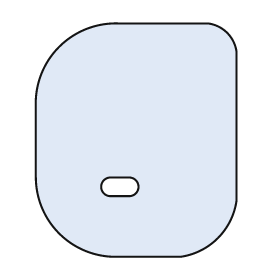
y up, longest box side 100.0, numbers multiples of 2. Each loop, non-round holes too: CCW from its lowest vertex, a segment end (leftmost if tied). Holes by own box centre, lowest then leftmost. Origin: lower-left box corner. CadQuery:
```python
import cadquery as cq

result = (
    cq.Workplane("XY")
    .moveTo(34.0, 0.0)
    .lineTo(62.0, 0.0)
    .threePointArc((78.0, 8.0), (86.0, 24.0))
    .lineTo(86.0, 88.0)
    .threePointArc((82.0, 96.0), (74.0, 100.0))
    .lineTo(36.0, 100.0)
    .threePointArc((10.0, 90.0), (0.0, 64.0))
    .lineTo(0.0, 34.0)
    .threePointArc((10.0, 10.0), (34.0, 0.0))
    .close()
    .moveTo(32.0, 26.0)
    .lineTo(40.0, 26.0)
    .threePointArc((44.0, 30.0), (40.0, 34.0))
    .lineTo(32.0, 34.0)
    .threePointArc((28.0, 30.0), (32.0, 26.0))
    .close()
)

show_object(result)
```